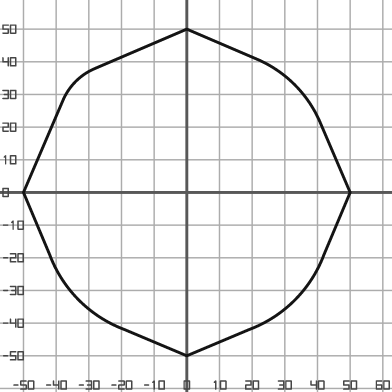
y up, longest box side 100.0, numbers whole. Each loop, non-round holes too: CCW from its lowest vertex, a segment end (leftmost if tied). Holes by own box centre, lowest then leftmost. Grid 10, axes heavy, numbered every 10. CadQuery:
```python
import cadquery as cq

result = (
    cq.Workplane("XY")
    .moveTo(0.0, -50.0)
    .lineTo(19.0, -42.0)
    .threePointArc((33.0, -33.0), (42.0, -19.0))
    .lineTo(50.0, 0.0)
    .lineTo(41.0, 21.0)
    .threePointArc((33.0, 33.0), (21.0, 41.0))
    .lineTo(0.0, 50.0)
    .lineTo(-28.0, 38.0)
    .threePointArc((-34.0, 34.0), (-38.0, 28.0))
    .lineTo(-50.0, 0.0)
    .lineTo(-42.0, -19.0)
    .threePointArc((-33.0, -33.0), (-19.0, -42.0))
    .close()
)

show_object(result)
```